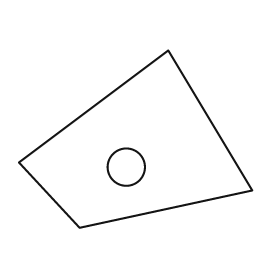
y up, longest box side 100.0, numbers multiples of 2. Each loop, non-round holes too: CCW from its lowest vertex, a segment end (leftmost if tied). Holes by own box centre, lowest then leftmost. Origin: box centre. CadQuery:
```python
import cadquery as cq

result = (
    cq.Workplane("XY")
    .moveTo(-24.0, -38.0)
    .lineTo(50.0, -22.0)
    .lineTo(14.0, 38.0)
    .lineTo(-50.0, -10.0)
    .close()
    .moveTo(-4.0, -12.0)
    .circle(8.0)
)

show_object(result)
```